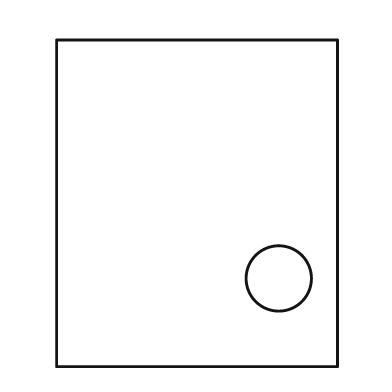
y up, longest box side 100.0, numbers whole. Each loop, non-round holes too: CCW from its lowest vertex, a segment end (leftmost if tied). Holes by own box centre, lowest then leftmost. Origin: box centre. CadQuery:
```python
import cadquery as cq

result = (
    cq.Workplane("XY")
    .moveTo(-43.0, -50.0)
    .lineTo(43.0, -50.0)
    .lineTo(43.0, 50.0)
    .lineTo(-43.0, 50.0)
    .close()
    .moveTo(25.0, -23.0)
    .circle(10.0)
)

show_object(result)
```